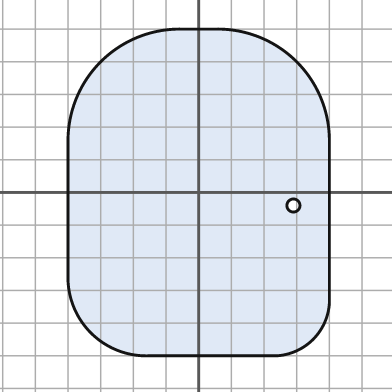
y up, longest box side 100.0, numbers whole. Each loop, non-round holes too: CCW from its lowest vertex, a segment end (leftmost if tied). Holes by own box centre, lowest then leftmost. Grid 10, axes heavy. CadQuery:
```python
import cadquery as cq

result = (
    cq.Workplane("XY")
    .moveTo(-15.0, -50.0)
    .lineTo(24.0, -50.0)
    .threePointArc((35.0, -45.0), (40.0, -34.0))
    .lineTo(40.0, 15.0)
    .threePointArc((30.0, 40.0), (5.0, 50.0))
    .lineTo(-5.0, 50.0)
    .threePointArc((-30.0, 40.0), (-40.0, 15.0))
    .lineTo(-40.0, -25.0)
    .threePointArc((-33.0, -43.0), (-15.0, -50.0))
    .close()
    .moveTo(29.0, -4.0)
    .circle(2.0)
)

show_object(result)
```